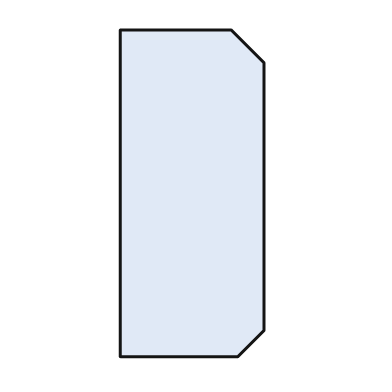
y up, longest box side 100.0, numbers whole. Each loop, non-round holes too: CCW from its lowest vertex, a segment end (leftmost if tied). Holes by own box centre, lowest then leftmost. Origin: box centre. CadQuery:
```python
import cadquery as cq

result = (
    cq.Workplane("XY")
    .moveTo(-22.0, -50.0)
    .lineTo(14.0, -50.0)
    .lineTo(22.0, -42.0)
    .lineTo(22.0, 40.0)
    .lineTo(12.0, 50.0)
    .lineTo(-22.0, 50.0)
    .close()
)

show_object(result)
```